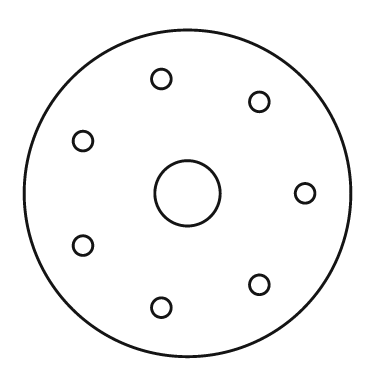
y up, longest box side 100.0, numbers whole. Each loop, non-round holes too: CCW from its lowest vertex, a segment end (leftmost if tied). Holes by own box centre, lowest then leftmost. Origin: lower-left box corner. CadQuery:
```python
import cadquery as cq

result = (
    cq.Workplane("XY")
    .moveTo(50.0, 50.0)
    .circle(50.0)
    .moveTo(42.0, 15.0)
    .circle(3.0)
    .moveTo(72.0, 22.0)
    .circle(3.0)
    .moveTo(18.0, 34.0)
    .circle(3.0)
    .moveTo(50.0, 50.0)
    .circle(10.0)
    .moveTo(86.0, 50.0)
    .circle(3.0)
    .moveTo(18.0, 66.0)
    .circle(3.0)
    .moveTo(72.0, 78.0)
    .circle(3.0)
    .moveTo(42.0, 85.0)
    .circle(3.0)
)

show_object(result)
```